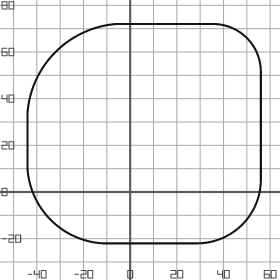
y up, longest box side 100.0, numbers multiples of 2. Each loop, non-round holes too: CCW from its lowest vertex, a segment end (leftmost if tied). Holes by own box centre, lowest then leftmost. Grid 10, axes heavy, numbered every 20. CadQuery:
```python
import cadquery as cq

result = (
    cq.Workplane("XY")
    .moveTo(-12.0, -22.0)
    .lineTo(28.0, -22.0)
    .threePointArc((48.0, -14.0), (56.0, 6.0))
    .lineTo(56.0, 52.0)
    .threePointArc((50.0, 66.0), (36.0, 72.0))
    .lineTo(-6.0, 72.0)
    .threePointArc((-32.0, 60.0), (-44.0, 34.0))
    .lineTo(-44.0, 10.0)
    .threePointArc((-34.0, -12.0), (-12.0, -22.0))
    .close()
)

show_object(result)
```